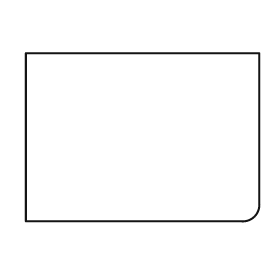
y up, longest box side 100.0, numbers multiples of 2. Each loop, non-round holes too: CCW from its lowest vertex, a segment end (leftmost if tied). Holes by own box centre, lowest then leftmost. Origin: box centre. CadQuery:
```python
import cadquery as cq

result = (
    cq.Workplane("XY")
    .moveTo(-50.0, -36.0)
    .lineTo(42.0, -36.0)
    .threePointArc((48.0, -34.0), (50.0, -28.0))
    .lineTo(50.0, 36.0)
    .lineTo(-50.0, 36.0)
    .close()
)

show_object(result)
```